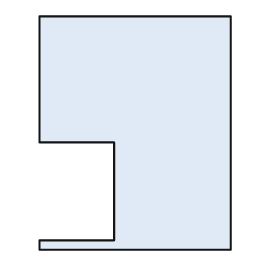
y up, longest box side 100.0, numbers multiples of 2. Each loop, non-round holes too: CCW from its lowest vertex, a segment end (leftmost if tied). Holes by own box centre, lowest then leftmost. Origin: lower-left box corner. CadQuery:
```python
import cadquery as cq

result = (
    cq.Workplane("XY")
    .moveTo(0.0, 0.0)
    .lineTo(82.0, 0.0)
    .lineTo(82.0, 100.0)
    .lineTo(0.0, 100.0)
    .lineTo(0.0, 46.0)
    .lineTo(32.0, 46.0)
    .lineTo(32.0, 4.0)
    .lineTo(0.0, 4.0)
    .close()
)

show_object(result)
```